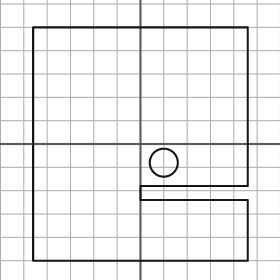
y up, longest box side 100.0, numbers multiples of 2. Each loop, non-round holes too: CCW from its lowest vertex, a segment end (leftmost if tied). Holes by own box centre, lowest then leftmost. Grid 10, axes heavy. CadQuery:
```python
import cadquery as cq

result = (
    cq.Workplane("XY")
    .moveTo(-46.0, -50.0)
    .lineTo(46.0, -50.0)
    .lineTo(46.0, -24.0)
    .lineTo(0.0, -24.0)
    .lineTo(0.0, -18.0)
    .lineTo(46.0, -18.0)
    .lineTo(46.0, 50.0)
    .lineTo(-46.0, 50.0)
    .close()
    .moveTo(10.0, -8.0)
    .circle(6.0)
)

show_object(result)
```